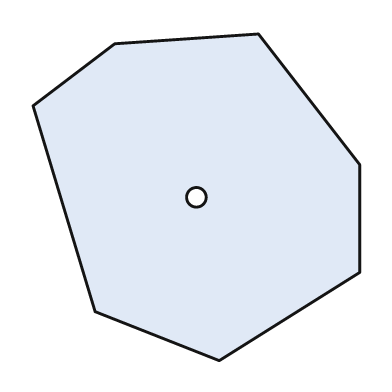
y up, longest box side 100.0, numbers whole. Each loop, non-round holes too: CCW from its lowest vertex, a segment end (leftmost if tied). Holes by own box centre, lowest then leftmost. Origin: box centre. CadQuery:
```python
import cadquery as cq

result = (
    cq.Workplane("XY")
    .moveTo(7.0, -50.0)
    .lineTo(50.0, -23.0)
    .lineTo(50.0, 10.0)
    .lineTo(19.0, 50.0)
    .lineTo(-25.0, 47.0)
    .lineTo(-50.0, 28.0)
    .lineTo(-31.0, -35.0)
    .close()
    .moveTo(0.0, 0.0)
    .circle(3.0)
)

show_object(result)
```